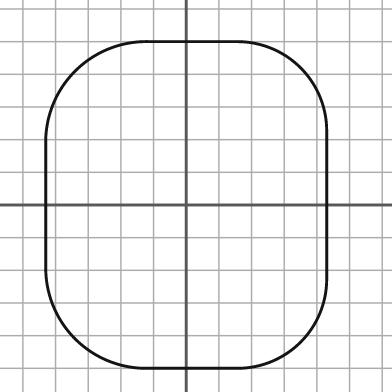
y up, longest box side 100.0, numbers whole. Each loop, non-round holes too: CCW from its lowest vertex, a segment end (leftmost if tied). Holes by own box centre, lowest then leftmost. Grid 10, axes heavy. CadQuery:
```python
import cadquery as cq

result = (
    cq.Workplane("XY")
    .moveTo(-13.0, -50.0)
    .lineTo(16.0, -50.0)
    .threePointArc((35.0, -42.0), (43.0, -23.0))
    .lineTo(43.0, 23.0)
    .threePointArc((35.0, 42.0), (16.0, 50.0))
    .lineTo(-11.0, 50.0)
    .threePointArc((-34.0, 41.0), (-43.0, 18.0))
    .lineTo(-43.0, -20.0)
    .threePointArc((-34.0, -41.0), (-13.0, -50.0))
    .close()
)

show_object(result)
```